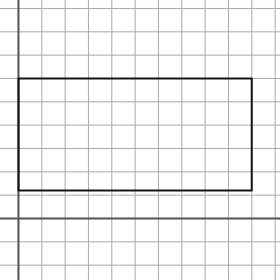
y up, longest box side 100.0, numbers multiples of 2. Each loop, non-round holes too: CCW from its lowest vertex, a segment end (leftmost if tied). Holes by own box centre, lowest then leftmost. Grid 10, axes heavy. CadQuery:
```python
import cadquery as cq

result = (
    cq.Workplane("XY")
    .moveTo(0.0, 12.0)
    .lineTo(100.0, 12.0)
    .lineTo(100.0, 60.0)
    .lineTo(0.0, 60.0)
    .close()
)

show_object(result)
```